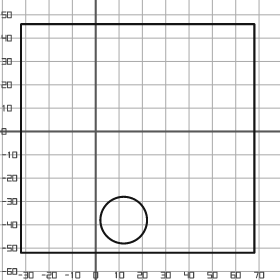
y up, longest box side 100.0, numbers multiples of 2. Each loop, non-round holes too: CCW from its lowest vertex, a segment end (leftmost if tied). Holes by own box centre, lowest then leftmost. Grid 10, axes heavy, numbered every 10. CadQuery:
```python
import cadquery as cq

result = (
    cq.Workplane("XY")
    .moveTo(-32.0, -52.0)
    .lineTo(68.0, -52.0)
    .lineTo(68.0, 46.0)
    .lineTo(-32.0, 46.0)
    .close()
    .moveTo(12.0, -38.0)
    .circle(10.0)
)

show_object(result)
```